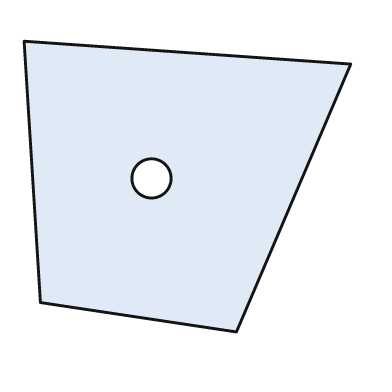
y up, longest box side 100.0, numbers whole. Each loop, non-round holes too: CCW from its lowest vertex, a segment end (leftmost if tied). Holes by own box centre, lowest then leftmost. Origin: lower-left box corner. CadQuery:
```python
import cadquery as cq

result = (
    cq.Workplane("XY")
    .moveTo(65.0, 0.0)
    .lineTo(100.0, 82.0)
    .lineTo(0.0, 89.0)
    .lineTo(5.0, 9.0)
    .close()
    .moveTo(39.0, 47.0)
    .circle(6.0)
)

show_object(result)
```